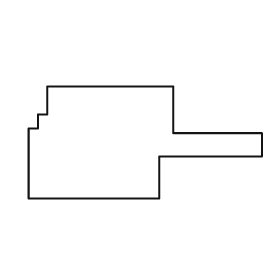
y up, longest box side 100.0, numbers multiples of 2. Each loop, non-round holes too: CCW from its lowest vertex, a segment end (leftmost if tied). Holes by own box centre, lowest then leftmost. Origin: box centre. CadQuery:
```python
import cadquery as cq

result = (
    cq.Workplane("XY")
    .moveTo(-50.0, -24.0)
    .lineTo(6.0, -24.0)
    .lineTo(6.0, -6.0)
    .lineTo(50.0, -6.0)
    .lineTo(50.0, 4.0)
    .lineTo(12.0, 4.0)
    .lineTo(12.0, 24.0)
    .lineTo(-42.0, 24.0)
    .lineTo(-42.0, 12.0)
    .lineTo(-46.0, 12.0)
    .lineTo(-46.0, 6.0)
    .lineTo(-50.0, 6.0)
    .close()
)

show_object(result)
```